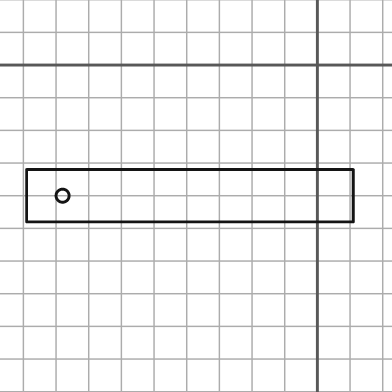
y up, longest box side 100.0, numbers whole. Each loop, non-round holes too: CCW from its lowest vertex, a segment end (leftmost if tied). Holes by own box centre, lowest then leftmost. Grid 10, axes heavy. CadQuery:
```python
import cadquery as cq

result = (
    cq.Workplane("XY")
    .moveTo(-89.0, -48.0)
    .lineTo(11.0, -48.0)
    .lineTo(11.0, -32.0)
    .lineTo(-89.0, -32.0)
    .close()
    .moveTo(-78.0, -40.0)
    .circle(2.0)
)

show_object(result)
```